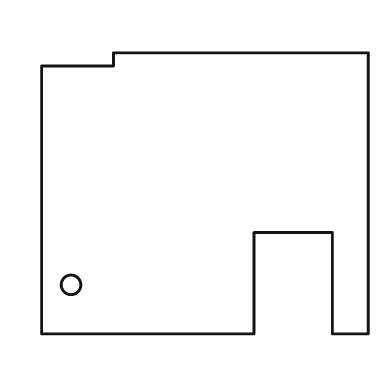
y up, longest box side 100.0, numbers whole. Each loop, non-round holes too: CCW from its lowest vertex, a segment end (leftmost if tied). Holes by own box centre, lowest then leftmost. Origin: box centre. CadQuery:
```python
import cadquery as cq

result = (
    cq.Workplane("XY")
    .moveTo(-50.0, -43.0)
    .lineTo(15.0, -43.0)
    .lineTo(15.0, -12.0)
    .lineTo(39.0, -12.0)
    .lineTo(39.0, -43.0)
    .lineTo(50.0, -43.0)
    .lineTo(50.0, 43.0)
    .lineTo(-28.0, 43.0)
    .lineTo(-28.0, 39.0)
    .lineTo(-50.0, 39.0)
    .close()
    .moveTo(-41.0, -28.0)
    .circle(3.0)
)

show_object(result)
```